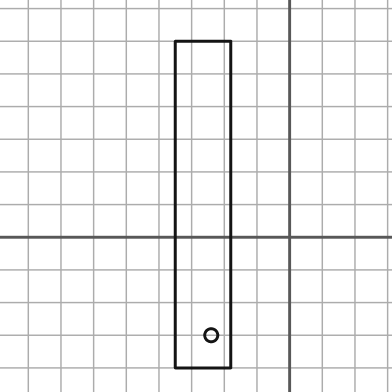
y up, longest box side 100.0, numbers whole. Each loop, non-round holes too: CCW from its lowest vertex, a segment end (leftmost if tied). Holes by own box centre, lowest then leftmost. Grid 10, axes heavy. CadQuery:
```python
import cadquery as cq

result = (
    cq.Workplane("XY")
    .moveTo(-35.0, -40.0)
    .lineTo(-18.0, -40.0)
    .lineTo(-18.0, 60.0)
    .lineTo(-35.0, 60.0)
    .close()
    .moveTo(-24.0, -30.0)
    .circle(2.0)
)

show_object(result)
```